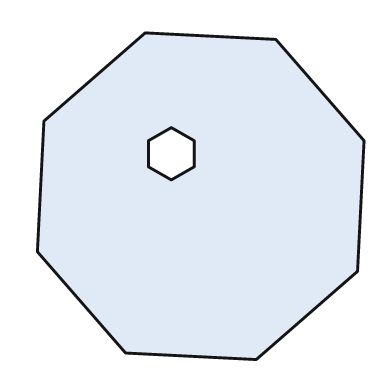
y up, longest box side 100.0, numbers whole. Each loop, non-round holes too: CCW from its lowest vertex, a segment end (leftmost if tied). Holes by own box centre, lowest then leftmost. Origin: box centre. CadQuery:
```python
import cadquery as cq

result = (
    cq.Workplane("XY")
    .moveTo(17.0, -50.0)
    .lineTo(48.0, -23.0)
    .lineTo(50.0, 17.0)
    .lineTo(23.0, 48.0)
    .lineTo(-17.0, 50.0)
    .lineTo(-48.0, 23.0)
    .lineTo(-50.0, -17.0)
    .lineTo(-23.0, -48.0)
    .close()
    .moveTo(-9.0, 5.0)
    .lineTo(-2.0, 9.0)
    .lineTo(-2.0, 17.0)
    .lineTo(-9.0, 21.0)
    .lineTo(-16.0, 17.0)
    .lineTo(-16.0, 9.0)
    .close()
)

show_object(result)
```